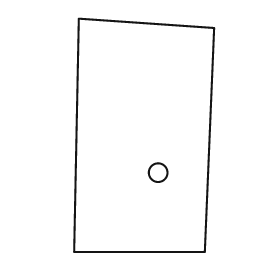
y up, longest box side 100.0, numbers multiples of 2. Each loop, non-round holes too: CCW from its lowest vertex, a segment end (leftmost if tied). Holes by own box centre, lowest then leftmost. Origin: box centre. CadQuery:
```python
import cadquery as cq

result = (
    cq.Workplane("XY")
    .moveTo(-30.0, -50.0)
    .lineTo(26.0, -50.0)
    .lineTo(30.0, 46.0)
    .lineTo(-28.0, 50.0)
    .close()
    .moveTo(6.0, -16.0)
    .circle(4.0)
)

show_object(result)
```